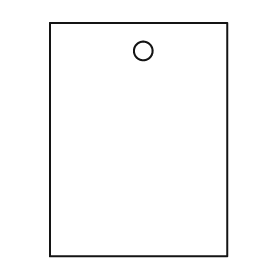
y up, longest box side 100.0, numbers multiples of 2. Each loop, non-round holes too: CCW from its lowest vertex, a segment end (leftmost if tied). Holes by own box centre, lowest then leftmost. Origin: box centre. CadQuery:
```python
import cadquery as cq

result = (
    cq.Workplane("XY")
    .moveTo(-38.0, -50.0)
    .lineTo(38.0, -50.0)
    .lineTo(38.0, 50.0)
    .lineTo(-38.0, 50.0)
    .close()
    .moveTo(2.0, 38.0)
    .circle(4.0)
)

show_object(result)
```